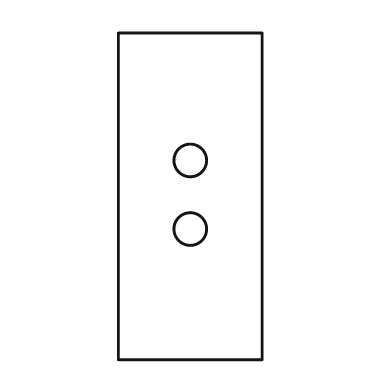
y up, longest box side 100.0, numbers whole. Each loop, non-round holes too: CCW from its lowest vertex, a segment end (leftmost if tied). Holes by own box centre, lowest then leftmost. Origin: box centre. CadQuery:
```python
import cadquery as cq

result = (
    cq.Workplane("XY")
    .moveTo(-22.0, -50.0)
    .lineTo(22.0, -50.0)
    .lineTo(22.0, 50.0)
    .lineTo(-22.0, 50.0)
    .close()
    .moveTo(0.0, -10.0)
    .circle(5.0)
    .moveTo(0.0, 11.0)
    .circle(5.0)
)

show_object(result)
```